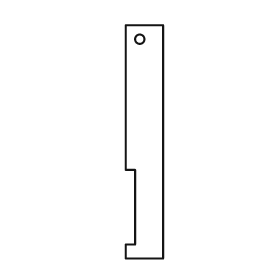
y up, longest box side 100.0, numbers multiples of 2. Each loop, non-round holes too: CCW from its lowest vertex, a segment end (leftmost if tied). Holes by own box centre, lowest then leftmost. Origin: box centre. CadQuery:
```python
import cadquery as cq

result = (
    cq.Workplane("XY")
    .moveTo(-8.0, -50.0)
    .lineTo(8.0, -50.0)
    .lineTo(8.0, 50.0)
    .lineTo(-8.0, 50.0)
    .lineTo(-8.0, -12.0)
    .lineTo(-4.0, -12.0)
    .lineTo(-4.0, -44.0)
    .lineTo(-8.0, -44.0)
    .close()
    .moveTo(-2.0, 44.0)
    .circle(2.0)
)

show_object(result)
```